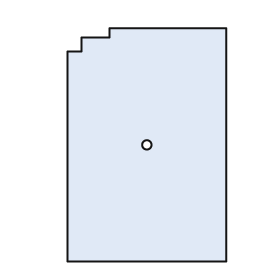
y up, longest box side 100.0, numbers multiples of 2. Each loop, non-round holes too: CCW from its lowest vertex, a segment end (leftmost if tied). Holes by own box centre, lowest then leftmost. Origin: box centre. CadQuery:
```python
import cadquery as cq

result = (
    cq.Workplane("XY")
    .moveTo(-34.0, -50.0)
    .lineTo(34.0, -50.0)
    .lineTo(34.0, 50.0)
    .lineTo(-16.0, 50.0)
    .lineTo(-16.0, 46.0)
    .lineTo(-28.0, 46.0)
    .lineTo(-28.0, 40.0)
    .lineTo(-34.0, 40.0)
    .close()
    .moveTo(0.0, 0.0)
    .circle(2.0)
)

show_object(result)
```